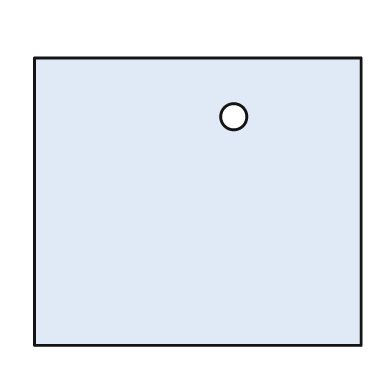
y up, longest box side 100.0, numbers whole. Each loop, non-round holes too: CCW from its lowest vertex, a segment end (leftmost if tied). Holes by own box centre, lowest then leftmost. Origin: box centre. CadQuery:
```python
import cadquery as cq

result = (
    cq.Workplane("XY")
    .moveTo(-50.0, -44.0)
    .lineTo(50.0, -44.0)
    .lineTo(50.0, 44.0)
    .lineTo(-50.0, 44.0)
    .close()
    .moveTo(11.0, 26.0)
    .circle(4.0)
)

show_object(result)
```